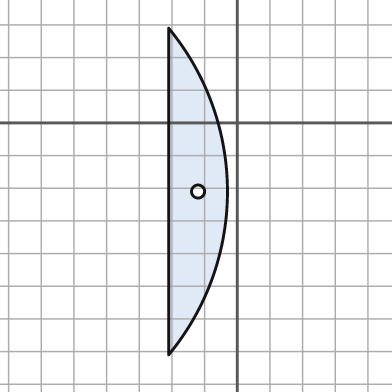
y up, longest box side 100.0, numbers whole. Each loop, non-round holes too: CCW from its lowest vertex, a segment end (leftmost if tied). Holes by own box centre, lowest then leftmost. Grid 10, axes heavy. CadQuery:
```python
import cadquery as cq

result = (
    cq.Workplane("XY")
    .moveTo(-21.0, -71.0)
    .threePointArc((-3.0, -21.0), (-21.0, 29.0))
    .close()
    .moveTo(-12.0, -21.0)
    .circle(2.0)
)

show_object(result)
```